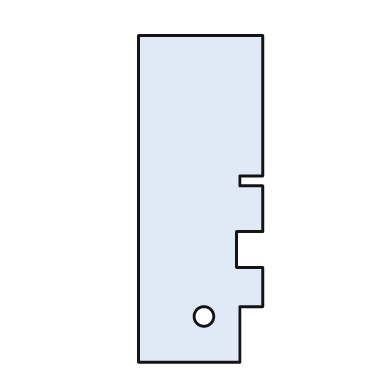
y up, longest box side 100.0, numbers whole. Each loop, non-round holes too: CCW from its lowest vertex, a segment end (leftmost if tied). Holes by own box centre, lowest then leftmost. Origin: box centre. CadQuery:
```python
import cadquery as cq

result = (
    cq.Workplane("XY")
    .moveTo(-19.0, -50.0)
    .lineTo(12.0, -50.0)
    .lineTo(12.0, -33.0)
    .lineTo(19.0, -33.0)
    .lineTo(19.0, -21.0)
    .lineTo(11.0, -21.0)
    .lineTo(11.0, -10.0)
    .lineTo(19.0, -10.0)
    .lineTo(19.0, 4.0)
    .lineTo(12.0, 4.0)
    .lineTo(12.0, 7.0)
    .lineTo(19.0, 7.0)
    .lineTo(19.0, 50.0)
    .lineTo(-19.0, 50.0)
    .close()
    .moveTo(1.0, -36.0)
    .circle(3.0)
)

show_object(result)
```